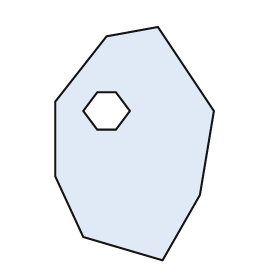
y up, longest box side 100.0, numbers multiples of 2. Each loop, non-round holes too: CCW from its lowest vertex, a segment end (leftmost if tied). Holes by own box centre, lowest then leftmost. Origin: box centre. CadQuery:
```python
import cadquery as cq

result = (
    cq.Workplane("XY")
    .moveTo(12.0, -50.0)
    .lineTo(28.0, -22.0)
    .lineTo(34.0, 14.0)
    .lineTo(10.0, 50.0)
    .lineTo(-12.0, 46.0)
    .lineTo(-34.0, 18.0)
    .lineTo(-34.0, -14.0)
    .lineTo(-22.0, -40.0)
    .close()
    .moveTo(-16.0, 6.0)
    .lineTo(-8.0, 6.0)
    .lineTo(-2.0, 14.0)
    .lineTo(-8.0, 22.0)
    .lineTo(-16.0, 22.0)
    .lineTo(-22.0, 14.0)
    .close()
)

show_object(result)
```